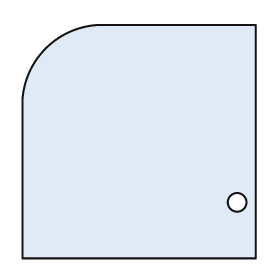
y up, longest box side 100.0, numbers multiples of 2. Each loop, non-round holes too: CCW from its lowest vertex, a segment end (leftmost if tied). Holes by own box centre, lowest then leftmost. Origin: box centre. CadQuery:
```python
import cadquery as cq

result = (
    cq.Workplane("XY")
    .moveTo(-50.0, -50.0)
    .lineTo(50.0, -50.0)
    .lineTo(50.0, 50.0)
    .lineTo(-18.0, 50.0)
    .threePointArc((-40.0, 40.0), (-50.0, 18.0))
    .close()
    .moveTo(42.0, -26.0)
    .circle(4.0)
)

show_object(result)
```